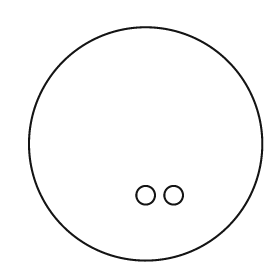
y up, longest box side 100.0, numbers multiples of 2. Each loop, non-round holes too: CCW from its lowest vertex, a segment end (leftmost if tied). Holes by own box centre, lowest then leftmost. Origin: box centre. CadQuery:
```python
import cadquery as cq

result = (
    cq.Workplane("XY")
    .moveTo(0.0, 0.0)
    .circle(50.0)
    .moveTo(0.0, -22.0)
    .circle(4.0)
    .moveTo(12.0, -22.0)
    .circle(4.0)
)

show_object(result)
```